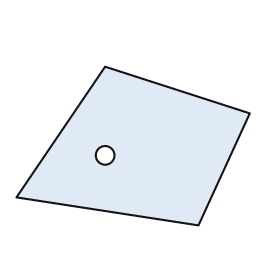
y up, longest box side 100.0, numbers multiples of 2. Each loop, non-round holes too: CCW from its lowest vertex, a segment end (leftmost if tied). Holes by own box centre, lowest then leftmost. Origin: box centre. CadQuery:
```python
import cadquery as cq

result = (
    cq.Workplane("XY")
    .moveTo(28.0, -34.0)
    .lineTo(50.0, 14.0)
    .lineTo(-12.0, 34.0)
    .lineTo(-50.0, -22.0)
    .close()
    .moveTo(-12.0, -4.0)
    .circle(4.0)
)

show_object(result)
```